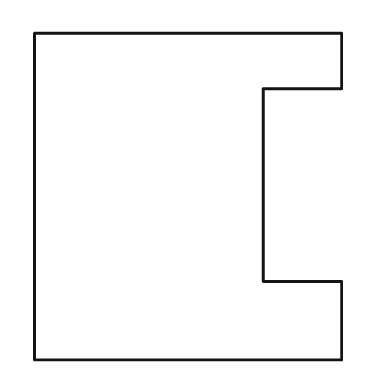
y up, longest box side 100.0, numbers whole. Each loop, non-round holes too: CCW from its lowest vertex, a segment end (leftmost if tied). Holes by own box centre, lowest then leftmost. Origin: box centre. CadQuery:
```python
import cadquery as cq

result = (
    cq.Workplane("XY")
    .moveTo(-47.0, -50.0)
    .lineTo(47.0, -50.0)
    .lineTo(47.0, -26.0)
    .lineTo(23.0, -26.0)
    .lineTo(23.0, 33.0)
    .lineTo(47.0, 33.0)
    .lineTo(47.0, 50.0)
    .lineTo(-47.0, 50.0)
    .close()
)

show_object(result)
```